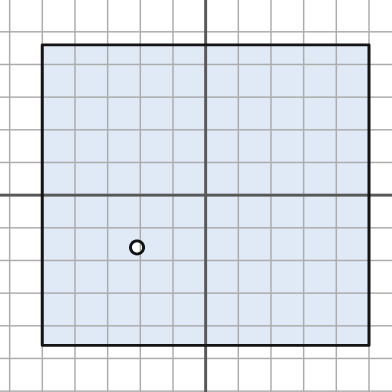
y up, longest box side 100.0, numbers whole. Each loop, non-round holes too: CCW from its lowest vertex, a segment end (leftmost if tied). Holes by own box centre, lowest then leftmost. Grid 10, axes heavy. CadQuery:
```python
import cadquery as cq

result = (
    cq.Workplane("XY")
    .moveTo(-50.0, -46.0)
    .lineTo(50.0, -46.0)
    .lineTo(50.0, 46.0)
    .lineTo(-50.0, 46.0)
    .close()
    .moveTo(-21.0, -16.0)
    .circle(2.0)
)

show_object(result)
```